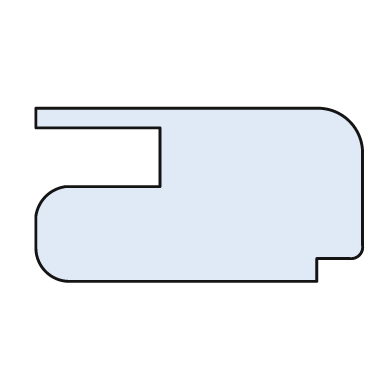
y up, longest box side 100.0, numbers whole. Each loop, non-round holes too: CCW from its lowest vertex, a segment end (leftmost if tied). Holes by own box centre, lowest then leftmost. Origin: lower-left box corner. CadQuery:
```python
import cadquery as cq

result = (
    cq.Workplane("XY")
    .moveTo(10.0, 0.0)
    .lineTo(86.0, 0.0)
    .lineTo(86.0, 7.0)
    .lineTo(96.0, 7.0)
    .threePointArc((99.0, 8.0), (100.0, 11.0))
    .lineTo(100.0, 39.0)
    .threePointArc((96.0, 49.0), (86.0, 53.0))
    .lineTo(0.0, 53.0)
    .lineTo(0.0, 47.0)
    .lineTo(38.0, 47.0)
    .lineTo(38.0, 29.0)
    .lineTo(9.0, 29.0)
    .threePointArc((3.0, 26.0), (0.0, 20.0))
    .lineTo(0.0, 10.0)
    .threePointArc((3.0, 3.0), (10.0, 0.0))
    .close()
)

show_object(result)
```